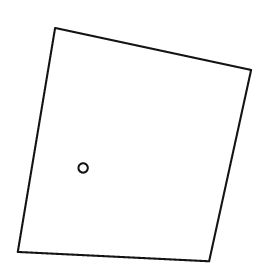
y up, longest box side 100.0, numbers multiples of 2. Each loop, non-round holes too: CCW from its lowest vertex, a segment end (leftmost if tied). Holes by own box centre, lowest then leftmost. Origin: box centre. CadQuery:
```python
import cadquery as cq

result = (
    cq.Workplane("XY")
    .moveTo(32.0, -50.0)
    .lineTo(50.0, 32.0)
    .lineTo(-34.0, 50.0)
    .lineTo(-50.0, -46.0)
    .close()
    .moveTo(-22.0, -10.0)
    .circle(2.0)
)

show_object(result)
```